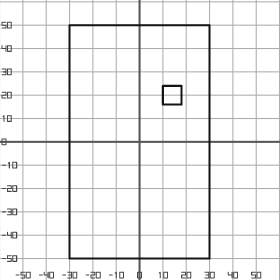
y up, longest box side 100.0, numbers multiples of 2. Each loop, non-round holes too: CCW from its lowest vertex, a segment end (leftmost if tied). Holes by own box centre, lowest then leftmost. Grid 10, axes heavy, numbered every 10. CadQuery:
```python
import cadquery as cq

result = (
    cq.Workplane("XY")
    .moveTo(-30.0, -50.0)
    .lineTo(30.0, -50.0)
    .lineTo(30.0, 50.0)
    .lineTo(-30.0, 50.0)
    .close()
    .moveTo(10.0, 16.0)
    .lineTo(18.0, 16.0)
    .lineTo(18.0, 24.0)
    .lineTo(10.0, 24.0)
    .close()
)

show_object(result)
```